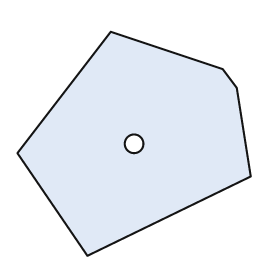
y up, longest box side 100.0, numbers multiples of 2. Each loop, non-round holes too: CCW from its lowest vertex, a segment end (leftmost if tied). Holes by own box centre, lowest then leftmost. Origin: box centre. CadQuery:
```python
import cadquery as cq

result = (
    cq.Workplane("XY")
    .moveTo(-20.0, -48.0)
    .lineTo(50.0, -14.0)
    .lineTo(44.0, 24.0)
    .lineTo(38.0, 32.0)
    .lineTo(-10.0, 48.0)
    .lineTo(-50.0, -4.0)
    .close()
    .moveTo(0.0, 0.0)
    .circle(4.0)
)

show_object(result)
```